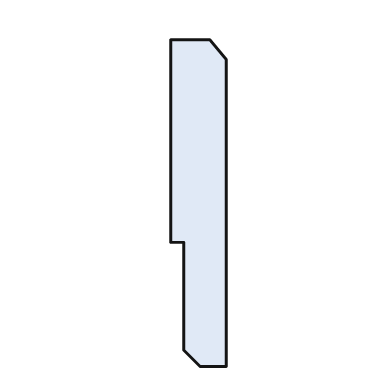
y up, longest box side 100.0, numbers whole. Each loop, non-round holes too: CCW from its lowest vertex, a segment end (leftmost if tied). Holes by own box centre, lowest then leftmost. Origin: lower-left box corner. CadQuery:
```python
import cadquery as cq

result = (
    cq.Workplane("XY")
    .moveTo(9.0, 0.0)
    .lineTo(17.0, 0.0)
    .lineTo(17.0, 94.0)
    .lineTo(12.0, 100.0)
    .lineTo(0.0, 100.0)
    .lineTo(0.0, 38.0)
    .lineTo(4.0, 38.0)
    .lineTo(4.0, 5.0)
    .close()
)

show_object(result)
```